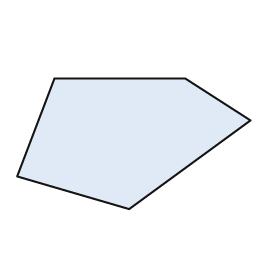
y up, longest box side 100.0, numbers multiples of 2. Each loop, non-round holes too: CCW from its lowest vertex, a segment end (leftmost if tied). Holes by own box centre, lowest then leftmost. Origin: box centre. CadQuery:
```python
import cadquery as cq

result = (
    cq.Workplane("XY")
    .moveTo(-2.0, -28.0)
    .lineTo(50.0, 10.0)
    .lineTo(22.0, 28.0)
    .lineTo(-34.0, 28.0)
    .lineTo(-50.0, -14.0)
    .close()
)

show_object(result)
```